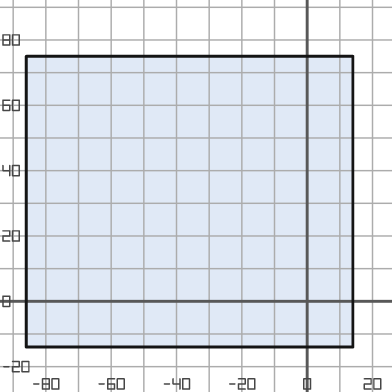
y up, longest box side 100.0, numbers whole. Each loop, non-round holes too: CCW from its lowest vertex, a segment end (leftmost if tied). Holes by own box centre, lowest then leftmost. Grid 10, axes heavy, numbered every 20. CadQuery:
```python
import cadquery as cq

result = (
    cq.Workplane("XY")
    .moveTo(-86.0, -14.0)
    .lineTo(14.0, -14.0)
    .lineTo(14.0, 75.0)
    .lineTo(-86.0, 75.0)
    .close()
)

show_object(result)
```